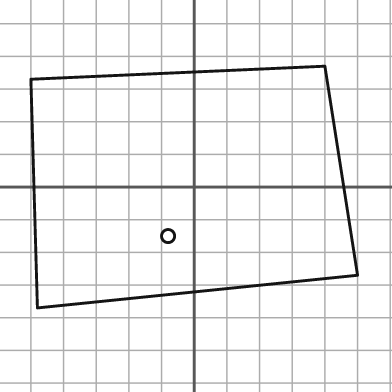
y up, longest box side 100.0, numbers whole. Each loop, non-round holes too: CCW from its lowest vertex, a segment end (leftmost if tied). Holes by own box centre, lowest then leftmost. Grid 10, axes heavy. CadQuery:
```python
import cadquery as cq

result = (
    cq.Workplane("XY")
    .moveTo(-48.0, -37.0)
    .lineTo(50.0, -27.0)
    .lineTo(40.0, 37.0)
    .lineTo(-50.0, 33.0)
    .close()
    .moveTo(-8.0, -15.0)
    .circle(2.0)
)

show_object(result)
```